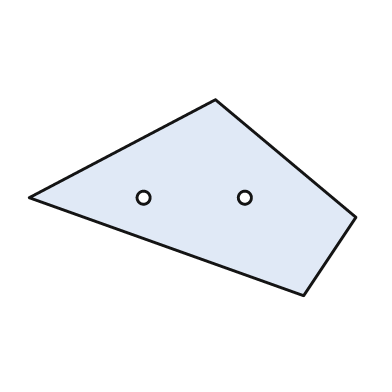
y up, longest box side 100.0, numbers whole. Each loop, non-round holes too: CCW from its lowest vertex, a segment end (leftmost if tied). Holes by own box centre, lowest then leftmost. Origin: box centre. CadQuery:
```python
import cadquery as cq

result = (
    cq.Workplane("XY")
    .moveTo(34.0, -30.0)
    .lineTo(50.0, -6.0)
    .lineTo(7.0, 30.0)
    .lineTo(-50.0, 0.0)
    .close()
    .moveTo(-15.0, 0.0)
    .circle(2.0)
    .moveTo(16.0, 0.0)
    .circle(2.0)
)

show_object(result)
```